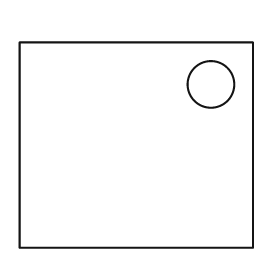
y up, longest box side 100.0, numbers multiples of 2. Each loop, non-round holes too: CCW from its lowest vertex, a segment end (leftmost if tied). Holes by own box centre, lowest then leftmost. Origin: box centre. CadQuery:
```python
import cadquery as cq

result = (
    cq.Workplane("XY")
    .moveTo(-50.0, -44.0)
    .lineTo(50.0, -44.0)
    .lineTo(50.0, 44.0)
    .lineTo(-50.0, 44.0)
    .close()
    .moveTo(32.0, 26.0)
    .circle(10.0)
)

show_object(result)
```